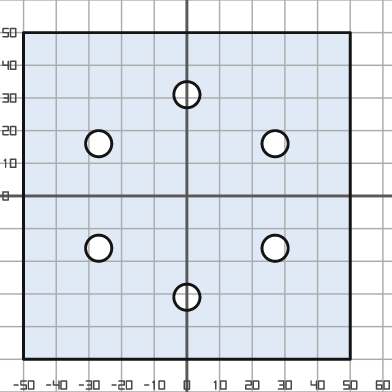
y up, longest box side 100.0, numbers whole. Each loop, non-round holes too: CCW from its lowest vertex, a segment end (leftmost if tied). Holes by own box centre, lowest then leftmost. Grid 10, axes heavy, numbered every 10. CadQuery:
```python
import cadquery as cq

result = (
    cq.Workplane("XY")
    .moveTo(-50.0, -50.0)
    .lineTo(50.0, -50.0)
    .lineTo(50.0, 50.0)
    .lineTo(-50.0, 50.0)
    .close()
    .moveTo(0.0, -31.0)
    .circle(4.0)
    .moveTo(-27.0, -16.0)
    .circle(4.0)
    .moveTo(27.0, -16.0)
    .circle(4.0)
    .moveTo(-27.0, 16.0)
    .circle(4.0)
    .moveTo(27.0, 16.0)
    .circle(4.0)
    .moveTo(0.0, 31.0)
    .circle(4.0)
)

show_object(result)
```